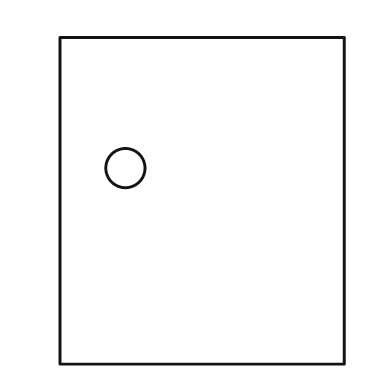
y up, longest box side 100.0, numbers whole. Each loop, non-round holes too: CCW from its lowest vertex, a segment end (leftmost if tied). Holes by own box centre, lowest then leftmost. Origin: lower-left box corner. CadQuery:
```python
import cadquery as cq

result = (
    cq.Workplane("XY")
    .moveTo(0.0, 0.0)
    .lineTo(87.0, 0.0)
    .lineTo(87.0, 100.0)
    .lineTo(0.0, 100.0)
    .close()
    .moveTo(20.0, 60.0)
    .circle(6.0)
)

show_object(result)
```